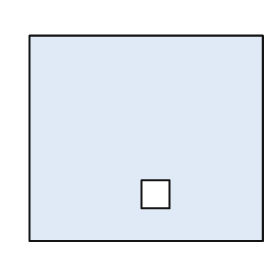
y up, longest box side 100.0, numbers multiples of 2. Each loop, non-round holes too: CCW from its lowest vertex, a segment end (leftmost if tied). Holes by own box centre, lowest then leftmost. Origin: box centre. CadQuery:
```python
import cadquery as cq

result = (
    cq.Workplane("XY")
    .moveTo(-50.0, -44.0)
    .lineTo(50.0, -44.0)
    .lineTo(50.0, 44.0)
    .lineTo(-50.0, 44.0)
    .close()
    .moveTo(-2.0, -30.0)
    .lineTo(10.0, -30.0)
    .lineTo(10.0, -18.0)
    .lineTo(-2.0, -18.0)
    .close()
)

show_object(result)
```